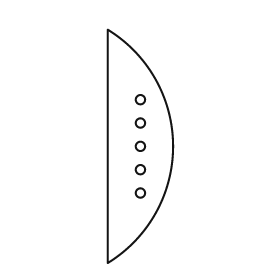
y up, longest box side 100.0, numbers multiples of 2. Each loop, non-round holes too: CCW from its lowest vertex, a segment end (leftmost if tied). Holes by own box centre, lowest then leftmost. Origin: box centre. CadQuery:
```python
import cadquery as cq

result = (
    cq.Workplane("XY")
    .moveTo(-14.0, -50.0)
    .threePointArc((14.0, 0.0), (-14.0, 50.0))
    .close()
    .moveTo(0.0, -20.0)
    .circle(2.0)
    .moveTo(0.0, -10.0)
    .circle(2.0)
    .moveTo(0.0, 0.0)
    .circle(2.0)
    .moveTo(0.0, 10.0)
    .circle(2.0)
    .moveTo(0.0, 20.0)
    .circle(2.0)
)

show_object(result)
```